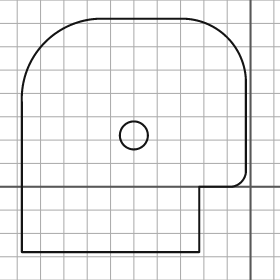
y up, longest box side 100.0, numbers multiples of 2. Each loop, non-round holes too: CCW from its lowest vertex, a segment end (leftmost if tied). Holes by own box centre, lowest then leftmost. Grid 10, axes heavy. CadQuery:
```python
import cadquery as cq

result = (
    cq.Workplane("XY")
    .moveTo(-98.0, -28.0)
    .lineTo(-22.0, -28.0)
    .lineTo(-22.0, 0.0)
    .lineTo(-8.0, 0.0)
    .threePointArc((-4.0, 2.0), (-2.0, 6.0))
    .lineTo(-2.0, 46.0)
    .threePointArc((-10.0, 64.0), (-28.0, 72.0))
    .lineTo(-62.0, 72.0)
    .threePointArc((-88.0, 62.0), (-98.0, 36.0))
    .close()
    .moveTo(-50.0, 22.0)
    .circle(6.0)
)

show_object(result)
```